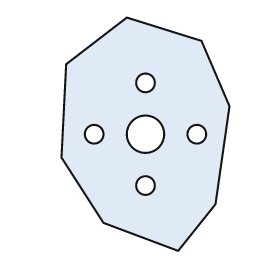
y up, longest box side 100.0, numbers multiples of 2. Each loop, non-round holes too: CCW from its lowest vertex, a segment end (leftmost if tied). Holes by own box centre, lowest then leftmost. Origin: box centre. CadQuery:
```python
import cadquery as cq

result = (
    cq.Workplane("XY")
    .moveTo(14.0, -50.0)
    .lineTo(30.0, -30.0)
    .lineTo(36.0, 12.0)
    .lineTo(24.0, 40.0)
    .lineTo(-8.0, 50.0)
    .lineTo(-34.0, 30.0)
    .lineTo(-36.0, -10.0)
    .lineTo(-18.0, -38.0)
    .close()
    .moveTo(0.0, -22.0)
    .circle(4.0)
    .moveTo(-22.0, 0.0)
    .circle(4.0)
    .moveTo(0.0, 0.0)
    .circle(8.0)
    .moveTo(22.0, 0.0)
    .circle(4.0)
    .moveTo(0.0, 22.0)
    .circle(4.0)
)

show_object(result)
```